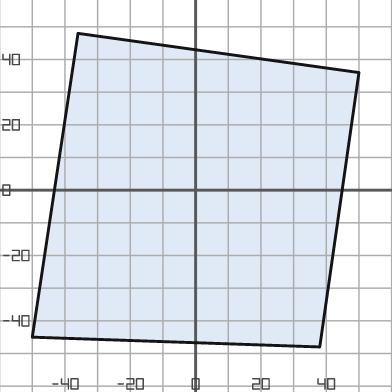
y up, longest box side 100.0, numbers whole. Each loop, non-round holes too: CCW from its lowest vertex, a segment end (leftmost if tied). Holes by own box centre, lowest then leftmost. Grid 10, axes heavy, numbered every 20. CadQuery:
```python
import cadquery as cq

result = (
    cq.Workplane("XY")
    .moveTo(38.0, -48.0)
    .lineTo(50.0, 36.0)
    .lineTo(-36.0, 48.0)
    .lineTo(-50.0, -45.0)
    .close()
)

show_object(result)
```